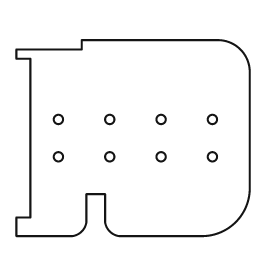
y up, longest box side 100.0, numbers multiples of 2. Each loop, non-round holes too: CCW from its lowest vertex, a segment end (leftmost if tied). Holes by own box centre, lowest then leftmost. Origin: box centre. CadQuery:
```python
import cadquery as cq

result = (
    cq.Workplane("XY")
    .moveTo(-50.0, -42.0)
    .lineTo(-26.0, -42.0)
    .threePointArc((-22.0, -40.0), (-20.0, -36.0))
    .lineTo(-20.0, -24.0)
    .lineTo(-12.0, -24.0)
    .lineTo(-12.0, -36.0)
    .threePointArc((-10.0, -40.0), (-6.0, -42.0))
    .lineTo(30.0, -42.0)
    .threePointArc((44.0, -36.0), (50.0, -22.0))
    .lineTo(50.0, 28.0)
    .threePointArc((46.0, 38.0), (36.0, 42.0))
    .lineTo(-22.0, 42.0)
    .lineTo(-22.0, 38.0)
    .lineTo(-50.0, 38.0)
    .lineTo(-50.0, 34.0)
    .lineTo(-44.0, 34.0)
    .lineTo(-44.0, -34.0)
    .lineTo(-50.0, -34.0)
    .close()
    .moveTo(-32.0, -8.0)
    .circle(2.0)
    .moveTo(-10.0, -8.0)
    .circle(2.0)
    .moveTo(12.0, -8.0)
    .circle(2.0)
    .moveTo(34.0, -8.0)
    .circle(2.0)
    .moveTo(-32.0, 8.0)
    .circle(2.0)
    .moveTo(-10.0, 8.0)
    .circle(2.0)
    .moveTo(12.0, 8.0)
    .circle(2.0)
    .moveTo(34.0, 8.0)
    .circle(2.0)
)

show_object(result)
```